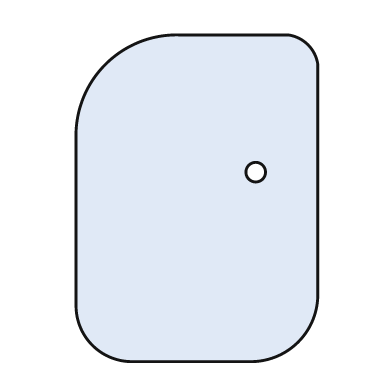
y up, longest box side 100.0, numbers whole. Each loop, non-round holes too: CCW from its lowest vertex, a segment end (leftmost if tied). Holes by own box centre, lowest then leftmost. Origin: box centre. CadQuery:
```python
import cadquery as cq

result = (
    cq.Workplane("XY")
    .moveTo(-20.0, -50.0)
    .lineTo(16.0, -50.0)
    .threePointArc((31.0, -44.0), (37.0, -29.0))
    .lineTo(37.0, 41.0)
    .threePointArc((34.0, 47.0), (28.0, 50.0))
    .lineTo(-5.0, 50.0)
    .threePointArc((-28.0, 41.0), (-37.0, 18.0))
    .lineTo(-37.0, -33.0)
    .threePointArc((-32.0, -45.0), (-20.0, -50.0))
    .close()
    .moveTo(18.0, 8.0)
    .circle(3.0)
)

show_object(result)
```